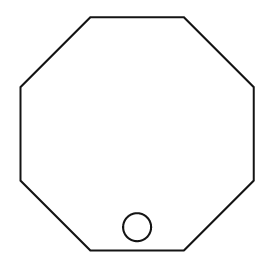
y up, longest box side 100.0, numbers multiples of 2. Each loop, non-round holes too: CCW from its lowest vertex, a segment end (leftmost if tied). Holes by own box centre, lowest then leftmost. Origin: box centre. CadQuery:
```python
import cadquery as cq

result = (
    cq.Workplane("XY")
    .moveTo(-20.0, -50.0)
    .lineTo(20.0, -50.0)
    .lineTo(50.0, -20.0)
    .lineTo(50.0, 20.0)
    .lineTo(20.0, 50.0)
    .lineTo(-20.0, 50.0)
    .lineTo(-50.0, 20.0)
    .lineTo(-50.0, -20.0)
    .close()
    .moveTo(0.0, -40.0)
    .circle(6.0)
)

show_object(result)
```